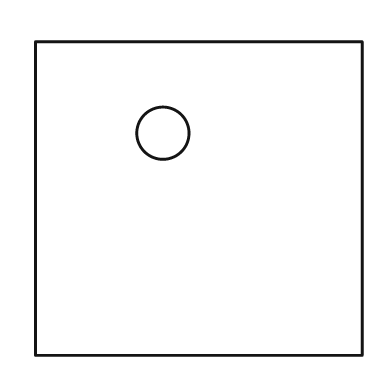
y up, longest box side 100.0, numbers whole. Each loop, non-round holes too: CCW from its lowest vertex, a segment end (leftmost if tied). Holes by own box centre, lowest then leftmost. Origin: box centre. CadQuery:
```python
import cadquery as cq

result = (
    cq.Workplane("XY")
    .moveTo(-50.0, -48.0)
    .lineTo(50.0, -48.0)
    .lineTo(50.0, 48.0)
    .lineTo(-50.0, 48.0)
    .close()
    .moveTo(-11.0, 20.0)
    .circle(8.0)
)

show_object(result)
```